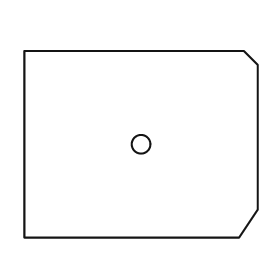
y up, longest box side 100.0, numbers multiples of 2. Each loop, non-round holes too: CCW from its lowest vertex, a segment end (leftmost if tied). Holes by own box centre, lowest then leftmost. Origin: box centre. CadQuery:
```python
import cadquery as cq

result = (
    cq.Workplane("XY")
    .moveTo(-50.0, -40.0)
    .lineTo(42.0, -40.0)
    .lineTo(50.0, -28.0)
    .lineTo(50.0, 34.0)
    .lineTo(44.0, 40.0)
    .lineTo(-50.0, 40.0)
    .close()
    .moveTo(0.0, 0.0)
    .circle(4.0)
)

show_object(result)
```